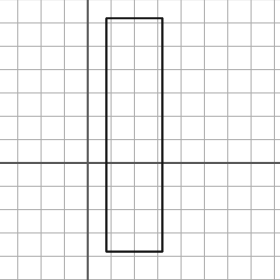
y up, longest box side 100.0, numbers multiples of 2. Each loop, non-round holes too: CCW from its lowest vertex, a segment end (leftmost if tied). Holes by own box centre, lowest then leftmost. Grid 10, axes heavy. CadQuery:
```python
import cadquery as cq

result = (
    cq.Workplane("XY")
    .moveTo(8.0, -38.0)
    .lineTo(32.0, -38.0)
    .lineTo(32.0, 62.0)
    .lineTo(8.0, 62.0)
    .close()
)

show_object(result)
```